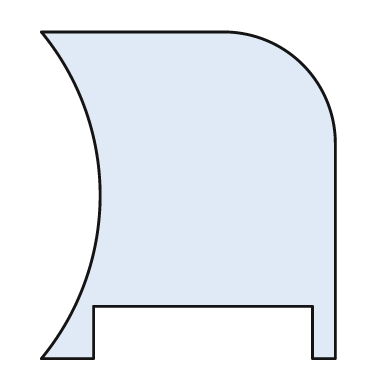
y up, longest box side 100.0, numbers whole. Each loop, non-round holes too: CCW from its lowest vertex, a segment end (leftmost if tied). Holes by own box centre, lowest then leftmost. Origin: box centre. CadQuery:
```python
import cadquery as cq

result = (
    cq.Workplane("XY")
    .moveTo(-45.0, -50.0)
    .lineTo(-29.0, -50.0)
    .lineTo(-29.0, -34.0)
    .lineTo(38.0, -34.0)
    .lineTo(38.0, -50.0)
    .lineTo(45.0, -50.0)
    .lineTo(45.0, 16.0)
    .threePointArc((35.0, 40.0), (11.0, 50.0))
    .lineTo(-45.0, 50.0)
    .threePointArc((-27.0, 0.0), (-45.0, -50.0))
    .close()
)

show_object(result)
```